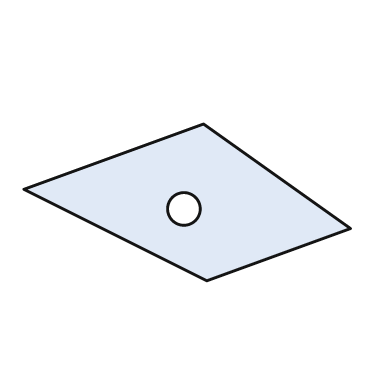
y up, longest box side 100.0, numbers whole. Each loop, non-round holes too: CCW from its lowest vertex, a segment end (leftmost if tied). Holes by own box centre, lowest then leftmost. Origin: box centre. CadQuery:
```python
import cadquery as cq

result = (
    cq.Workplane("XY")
    .moveTo(6.0, -24.0)
    .lineTo(50.0, -8.0)
    .lineTo(5.0, 24.0)
    .lineTo(-50.0, 4.0)
    .close()
    .moveTo(-1.0, -2.0)
    .circle(5.0)
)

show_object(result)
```